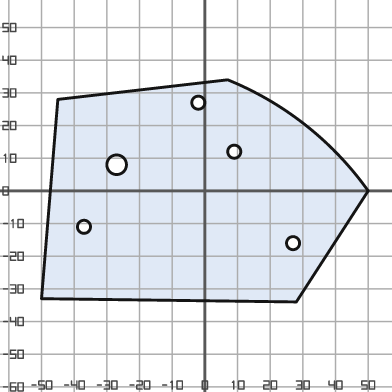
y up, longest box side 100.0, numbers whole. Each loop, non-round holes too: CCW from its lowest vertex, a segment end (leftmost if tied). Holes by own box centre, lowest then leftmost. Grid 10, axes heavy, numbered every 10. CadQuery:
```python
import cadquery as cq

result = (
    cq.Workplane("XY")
    .moveTo(28.0, -34.0)
    .lineTo(50.0, 0.0)
    .threePointArc((31.0, 20.0), (7.0, 34.0))
    .lineTo(-45.0, 28.0)
    .lineTo(-50.0, -33.0)
    .close()
    .moveTo(27.0, -16.0)
    .circle(2.0)
    .moveTo(-37.0, -11.0)
    .circle(2.0)
    .moveTo(-27.0, 8.0)
    .circle(3.0)
    .moveTo(9.0, 12.0)
    .circle(2.0)
    .moveTo(-2.0, 27.0)
    .circle(2.0)
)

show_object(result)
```